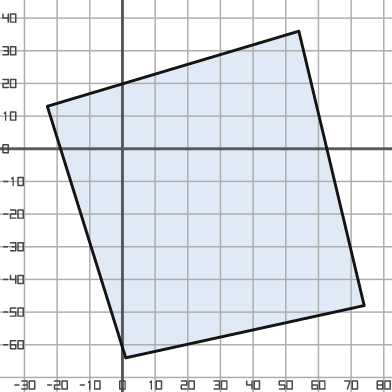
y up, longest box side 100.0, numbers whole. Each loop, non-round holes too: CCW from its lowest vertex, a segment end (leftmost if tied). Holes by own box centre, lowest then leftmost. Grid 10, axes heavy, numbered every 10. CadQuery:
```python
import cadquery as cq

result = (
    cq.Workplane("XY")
    .moveTo(1.0, -64.0)
    .lineTo(74.0, -48.0)
    .lineTo(54.0, 36.0)
    .lineTo(-23.0, 13.0)
    .close()
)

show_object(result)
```